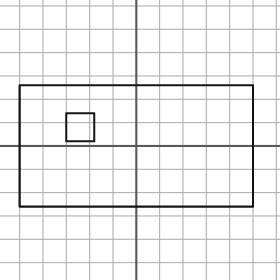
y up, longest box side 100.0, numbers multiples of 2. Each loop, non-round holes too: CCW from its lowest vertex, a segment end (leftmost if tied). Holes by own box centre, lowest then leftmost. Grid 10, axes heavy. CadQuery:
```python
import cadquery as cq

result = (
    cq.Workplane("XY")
    .moveTo(-50.0, -26.0)
    .lineTo(50.0, -26.0)
    .lineTo(50.0, 26.0)
    .lineTo(-50.0, 26.0)
    .close()
    .moveTo(-30.0, 2.0)
    .lineTo(-18.0, 2.0)
    .lineTo(-18.0, 14.0)
    .lineTo(-30.0, 14.0)
    .close()
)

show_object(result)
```